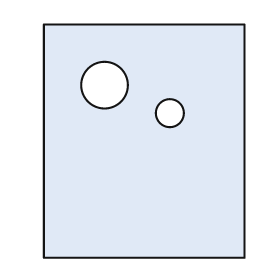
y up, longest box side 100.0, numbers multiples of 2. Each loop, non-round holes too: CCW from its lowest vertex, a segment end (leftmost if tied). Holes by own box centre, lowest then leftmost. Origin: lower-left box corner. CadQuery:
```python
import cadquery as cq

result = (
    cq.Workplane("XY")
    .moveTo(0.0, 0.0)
    .lineTo(86.0, 0.0)
    .lineTo(86.0, 100.0)
    .lineTo(0.0, 100.0)
    .close()
    .moveTo(54.0, 62.0)
    .circle(6.0)
    .moveTo(26.0, 74.0)
    .circle(10.0)
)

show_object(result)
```